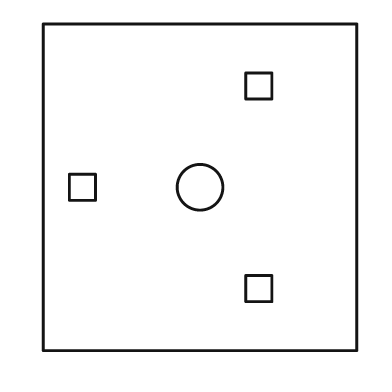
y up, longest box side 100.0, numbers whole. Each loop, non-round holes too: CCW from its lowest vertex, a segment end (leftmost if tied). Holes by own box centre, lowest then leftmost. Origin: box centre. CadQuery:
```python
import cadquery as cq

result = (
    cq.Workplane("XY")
    .moveTo(-48.0, -50.0)
    .lineTo(48.0, -50.0)
    .lineTo(48.0, 50.0)
    .lineTo(-48.0, 50.0)
    .close()
    .moveTo(14.0, -35.0)
    .lineTo(22.0, -35.0)
    .lineTo(22.0, -27.0)
    .lineTo(14.0, -27.0)
    .close()
    .moveTo(-40.0, -4.0)
    .lineTo(-32.0, -4.0)
    .lineTo(-32.0, 4.0)
    .lineTo(-40.0, 4.0)
    .close()
    .moveTo(0.0, 0.0)
    .circle(7.0)
    .moveTo(14.0, 27.0)
    .lineTo(22.0, 27.0)
    .lineTo(22.0, 35.0)
    .lineTo(14.0, 35.0)
    .close()
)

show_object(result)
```